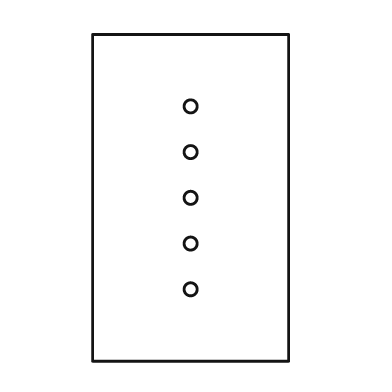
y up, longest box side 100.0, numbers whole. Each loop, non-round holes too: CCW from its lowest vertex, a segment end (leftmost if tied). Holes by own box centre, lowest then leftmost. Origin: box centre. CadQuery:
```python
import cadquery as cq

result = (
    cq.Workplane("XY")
    .moveTo(-30.0, -50.0)
    .lineTo(30.0, -50.0)
    .lineTo(30.0, 50.0)
    .lineTo(-30.0, 50.0)
    .close()
    .moveTo(0.0, -28.0)
    .circle(2.0)
    .moveTo(0.0, -14.0)
    .circle(2.0)
    .moveTo(0.0, 0.0)
    .circle(2.0)
    .moveTo(0.0, 14.0)
    .circle(2.0)
    .moveTo(0.0, 28.0)
    .circle(2.0)
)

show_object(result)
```